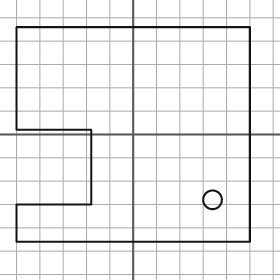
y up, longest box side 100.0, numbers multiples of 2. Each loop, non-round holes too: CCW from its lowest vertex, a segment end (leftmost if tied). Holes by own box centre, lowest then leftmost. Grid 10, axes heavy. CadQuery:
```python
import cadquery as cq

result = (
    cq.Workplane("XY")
    .moveTo(-50.0, -46.0)
    .lineTo(50.0, -46.0)
    .lineTo(50.0, 46.0)
    .lineTo(-50.0, 46.0)
    .lineTo(-50.0, 2.0)
    .lineTo(-18.0, 2.0)
    .lineTo(-18.0, -30.0)
    .lineTo(-50.0, -30.0)
    .close()
    .moveTo(34.0, -28.0)
    .circle(4.0)
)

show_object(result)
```